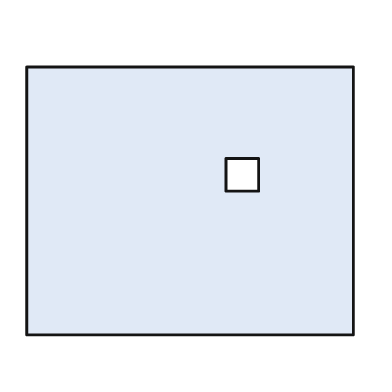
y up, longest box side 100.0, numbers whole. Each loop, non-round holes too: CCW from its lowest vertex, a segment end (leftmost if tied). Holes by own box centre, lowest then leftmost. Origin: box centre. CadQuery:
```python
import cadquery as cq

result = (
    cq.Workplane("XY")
    .moveTo(-50.0, -41.0)
    .lineTo(50.0, -41.0)
    .lineTo(50.0, 41.0)
    .lineTo(-50.0, 41.0)
    .close()
    .moveTo(11.0, 3.0)
    .lineTo(21.0, 3.0)
    .lineTo(21.0, 13.0)
    .lineTo(11.0, 13.0)
    .close()
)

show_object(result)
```